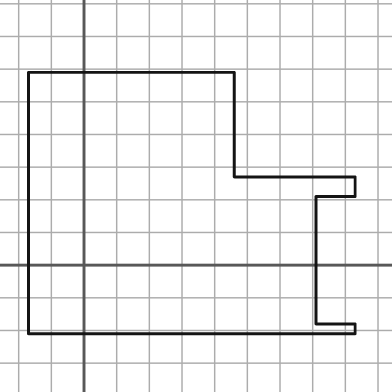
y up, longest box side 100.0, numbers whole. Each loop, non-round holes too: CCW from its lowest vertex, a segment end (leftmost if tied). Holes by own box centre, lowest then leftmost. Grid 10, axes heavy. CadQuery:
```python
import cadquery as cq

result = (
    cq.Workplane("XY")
    .moveTo(-17.0, -21.0)
    .lineTo(83.0, -21.0)
    .lineTo(83.0, -18.0)
    .lineTo(71.0, -18.0)
    .lineTo(71.0, 21.0)
    .lineTo(83.0, 21.0)
    .lineTo(83.0, 27.0)
    .lineTo(46.0, 27.0)
    .lineTo(46.0, 59.0)
    .lineTo(-17.0, 59.0)
    .close()
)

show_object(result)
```